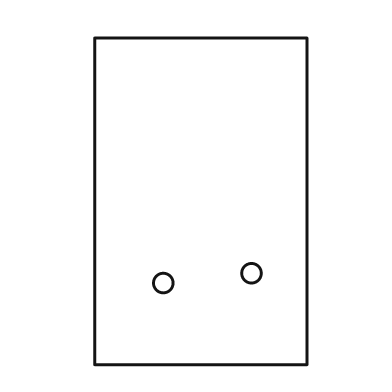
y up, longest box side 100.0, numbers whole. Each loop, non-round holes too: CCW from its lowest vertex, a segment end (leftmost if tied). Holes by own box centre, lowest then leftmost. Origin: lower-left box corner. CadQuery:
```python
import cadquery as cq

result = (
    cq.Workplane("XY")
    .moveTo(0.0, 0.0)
    .lineTo(65.0, 0.0)
    .lineTo(65.0, 100.0)
    .lineTo(0.0, 100.0)
    .close()
    .moveTo(21.0, 25.0)
    .circle(3.0)
    .moveTo(48.0, 28.0)
    .circle(3.0)
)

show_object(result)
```